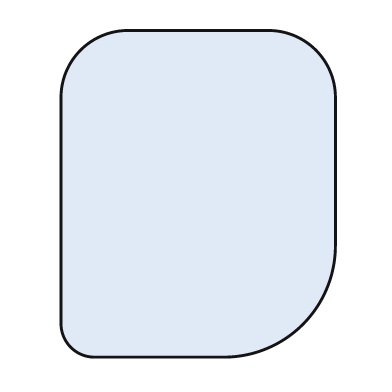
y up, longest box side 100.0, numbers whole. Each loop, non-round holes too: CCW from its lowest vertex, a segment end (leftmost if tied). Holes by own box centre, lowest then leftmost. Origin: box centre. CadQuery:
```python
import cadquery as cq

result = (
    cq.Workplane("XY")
    .moveTo(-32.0, -50.0)
    .lineTo(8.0, -50.0)
    .threePointArc((32.0, -40.0), (42.0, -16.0))
    .lineTo(42.0, 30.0)
    .threePointArc((36.0, 44.0), (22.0, 50.0))
    .lineTo(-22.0, 50.0)
    .threePointArc((-36.0, 44.0), (-42.0, 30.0))
    .lineTo(-42.0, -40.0)
    .threePointArc((-39.0, -47.0), (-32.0, -50.0))
    .close()
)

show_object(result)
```